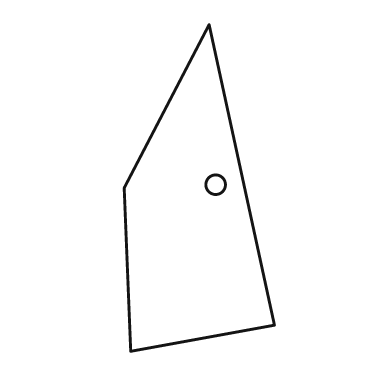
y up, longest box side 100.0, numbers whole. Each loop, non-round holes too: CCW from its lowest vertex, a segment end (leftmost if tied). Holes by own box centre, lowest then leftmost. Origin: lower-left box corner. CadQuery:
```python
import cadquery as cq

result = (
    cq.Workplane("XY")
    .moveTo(2.0, 0.0)
    .lineTo(46.0, 8.0)
    .lineTo(26.0, 100.0)
    .lineTo(0.0, 50.0)
    .close()
    .moveTo(28.0, 51.0)
    .circle(3.0)
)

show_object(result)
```